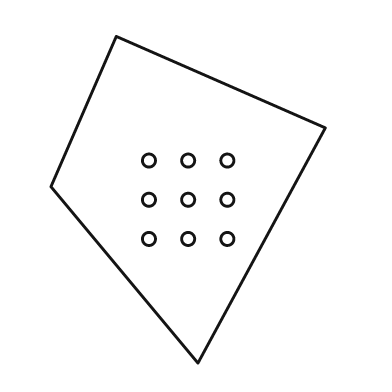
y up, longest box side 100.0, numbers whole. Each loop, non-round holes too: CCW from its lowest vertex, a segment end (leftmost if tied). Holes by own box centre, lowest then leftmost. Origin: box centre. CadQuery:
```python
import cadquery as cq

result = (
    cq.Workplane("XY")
    .moveTo(3.0, -50.0)
    .lineTo(42.0, 22.0)
    .lineTo(-22.0, 50.0)
    .lineTo(-42.0, 4.0)
    .close()
    .moveTo(-12.0, -12.0)
    .circle(2.0)
    .moveTo(0.0, -12.0)
    .circle(2.0)
    .moveTo(12.0, -12.0)
    .circle(2.0)
    .moveTo(-12.0, 0.0)
    .circle(2.0)
    .moveTo(0.0, 0.0)
    .circle(2.0)
    .moveTo(12.0, 0.0)
    .circle(2.0)
    .moveTo(-12.0, 12.0)
    .circle(2.0)
    .moveTo(0.0, 12.0)
    .circle(2.0)
    .moveTo(12.0, 12.0)
    .circle(2.0)
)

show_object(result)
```